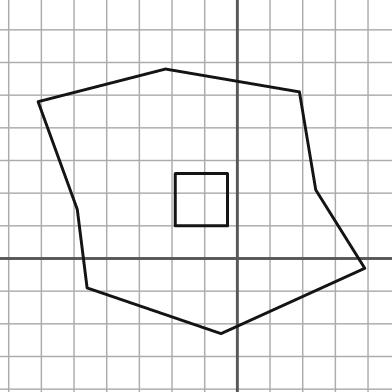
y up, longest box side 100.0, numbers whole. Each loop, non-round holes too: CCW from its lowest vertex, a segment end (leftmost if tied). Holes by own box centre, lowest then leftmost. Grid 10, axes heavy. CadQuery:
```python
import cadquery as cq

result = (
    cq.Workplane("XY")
    .moveTo(-5.0, -23.0)
    .lineTo(39.0, -3.0)
    .lineTo(24.0, 21.0)
    .lineTo(19.0, 51.0)
    .lineTo(-22.0, 58.0)
    .lineTo(-61.0, 48.0)
    .lineTo(-49.0, 15.0)
    .lineTo(-46.0, -9.0)
    .close()
    .moveTo(-19.0, 10.0)
    .lineTo(-3.0, 10.0)
    .lineTo(-3.0, 26.0)
    .lineTo(-19.0, 26.0)
    .close()
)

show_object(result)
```